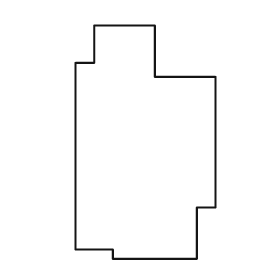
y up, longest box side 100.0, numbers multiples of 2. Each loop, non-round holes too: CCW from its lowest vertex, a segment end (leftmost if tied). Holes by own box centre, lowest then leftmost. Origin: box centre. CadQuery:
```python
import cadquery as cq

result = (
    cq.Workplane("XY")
    .moveTo(-14.0, -50.0)
    .lineTo(22.0, -50.0)
    .lineTo(22.0, -28.0)
    .lineTo(30.0, -28.0)
    .lineTo(30.0, 28.0)
    .lineTo(4.0, 28.0)
    .lineTo(4.0, 50.0)
    .lineTo(-22.0, 50.0)
    .lineTo(-22.0, 34.0)
    .lineTo(-30.0, 34.0)
    .lineTo(-30.0, -46.0)
    .lineTo(-14.0, -46.0)
    .close()
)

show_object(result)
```